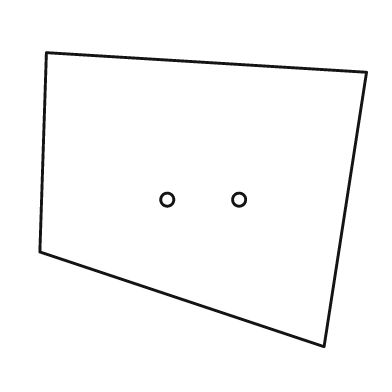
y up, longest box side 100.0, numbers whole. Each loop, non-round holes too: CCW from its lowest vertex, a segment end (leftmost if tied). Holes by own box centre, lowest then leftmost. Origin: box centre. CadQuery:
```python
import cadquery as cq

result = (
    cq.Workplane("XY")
    .moveTo(37.0, -45.0)
    .lineTo(50.0, 39.0)
    .lineTo(-48.0, 45.0)
    .lineTo(-50.0, -16.0)
    .close()
    .moveTo(-11.0, 0.0)
    .circle(2.0)
    .moveTo(11.0, 0.0)
    .circle(2.0)
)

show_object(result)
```